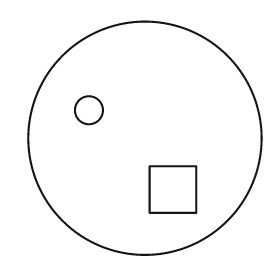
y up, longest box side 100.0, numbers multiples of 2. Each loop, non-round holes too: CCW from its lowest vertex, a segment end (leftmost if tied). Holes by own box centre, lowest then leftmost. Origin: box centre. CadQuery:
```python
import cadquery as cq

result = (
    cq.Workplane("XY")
    .moveTo(0.0, 0.0)
    .circle(50.0)
    .moveTo(2.0, -32.0)
    .lineTo(22.0, -32.0)
    .lineTo(22.0, -12.0)
    .lineTo(2.0, -12.0)
    .close()
    .moveTo(-24.0, 12.0)
    .circle(6.0)
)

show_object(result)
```